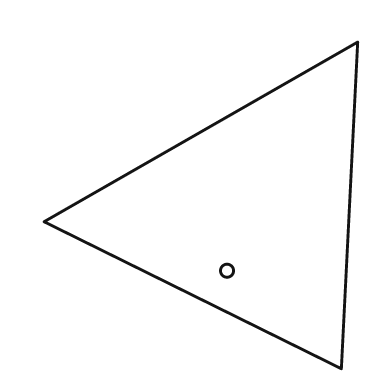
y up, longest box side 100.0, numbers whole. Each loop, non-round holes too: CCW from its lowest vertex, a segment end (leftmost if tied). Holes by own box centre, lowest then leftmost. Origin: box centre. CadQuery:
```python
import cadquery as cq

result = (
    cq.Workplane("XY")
    .moveTo(43.0, -50.0)
    .lineTo(48.0, 50.0)
    .lineTo(-48.0, -5.0)
    .close()
    .moveTo(8.0, -20.0)
    .circle(2.0)
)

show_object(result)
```